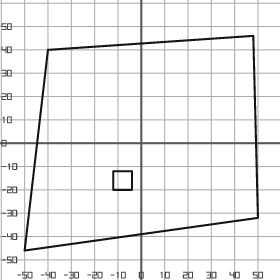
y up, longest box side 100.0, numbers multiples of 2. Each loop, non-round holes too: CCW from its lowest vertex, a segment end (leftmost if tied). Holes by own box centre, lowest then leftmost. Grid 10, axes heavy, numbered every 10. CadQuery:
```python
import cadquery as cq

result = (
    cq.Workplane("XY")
    .moveTo(-50.0, -46.0)
    .lineTo(50.0, -32.0)
    .lineTo(48.0, 46.0)
    .lineTo(-40.0, 40.0)
    .close()
    .moveTo(-12.0, -20.0)
    .lineTo(-4.0, -20.0)
    .lineTo(-4.0, -12.0)
    .lineTo(-12.0, -12.0)
    .close()
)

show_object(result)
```